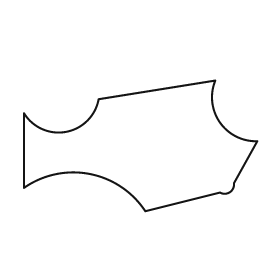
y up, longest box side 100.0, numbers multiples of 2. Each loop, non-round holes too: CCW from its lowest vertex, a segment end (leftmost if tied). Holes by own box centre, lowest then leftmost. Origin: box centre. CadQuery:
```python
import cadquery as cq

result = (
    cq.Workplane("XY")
    .moveTo(2.0, -28.0)
    .lineTo(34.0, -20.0)
    .threePointArc((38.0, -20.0), (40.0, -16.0))
    .lineTo(50.0, 2.0)
    .threePointArc((34.0, 10.0), (32.0, 28.0))
    .lineTo(-18.0, 20.0)
    .threePointArc((-32.0, 6.0), (-50.0, 14.0))
    .lineTo(-50.0, -18.0)
    .threePointArc((-22.0, -12.0), (2.0, -28.0))
    .close()
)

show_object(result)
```